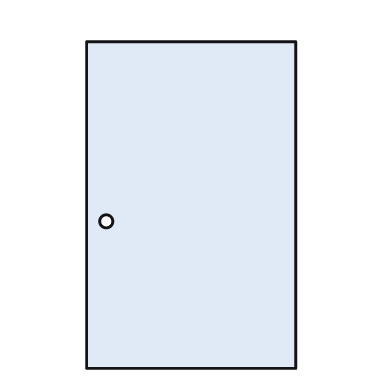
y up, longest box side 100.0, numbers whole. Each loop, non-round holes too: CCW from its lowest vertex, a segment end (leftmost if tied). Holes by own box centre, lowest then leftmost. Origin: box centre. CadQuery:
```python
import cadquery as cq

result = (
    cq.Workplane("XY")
    .moveTo(-32.0, -50.0)
    .lineTo(32.0, -50.0)
    .lineTo(32.0, 50.0)
    .lineTo(-32.0, 50.0)
    .close()
    .moveTo(-26.0, -5.0)
    .circle(2.0)
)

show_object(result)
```